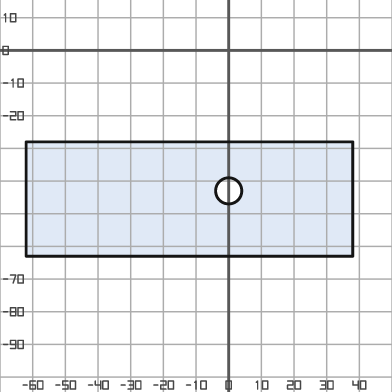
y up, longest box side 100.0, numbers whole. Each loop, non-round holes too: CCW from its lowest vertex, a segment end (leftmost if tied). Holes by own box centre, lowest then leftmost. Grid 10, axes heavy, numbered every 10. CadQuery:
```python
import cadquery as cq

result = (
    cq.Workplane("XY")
    .moveTo(-62.0, -63.0)
    .lineTo(38.0, -63.0)
    .lineTo(38.0, -28.0)
    .lineTo(-62.0, -28.0)
    .close()
    .moveTo(0.0, -43.0)
    .circle(4.0)
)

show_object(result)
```